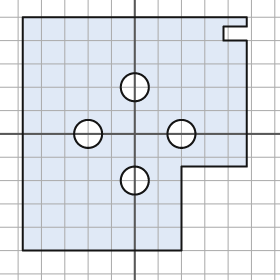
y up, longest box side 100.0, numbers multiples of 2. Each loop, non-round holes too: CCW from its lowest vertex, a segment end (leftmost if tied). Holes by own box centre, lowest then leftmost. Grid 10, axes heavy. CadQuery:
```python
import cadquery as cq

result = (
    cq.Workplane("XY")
    .moveTo(-48.0, -50.0)
    .lineTo(20.0, -50.0)
    .lineTo(20.0, -14.0)
    .lineTo(48.0, -14.0)
    .lineTo(48.0, 40.0)
    .lineTo(38.0, 40.0)
    .lineTo(38.0, 46.0)
    .lineTo(48.0, 46.0)
    .lineTo(48.0, 50.0)
    .lineTo(-48.0, 50.0)
    .close()
    .moveTo(0.0, -20.0)
    .circle(6.0)
    .moveTo(-20.0, 0.0)
    .circle(6.0)
    .moveTo(20.0, 0.0)
    .circle(6.0)
    .moveTo(0.0, 20.0)
    .circle(6.0)
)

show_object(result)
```